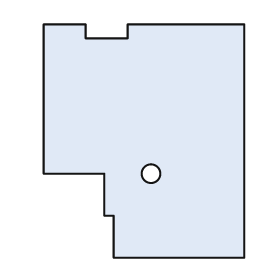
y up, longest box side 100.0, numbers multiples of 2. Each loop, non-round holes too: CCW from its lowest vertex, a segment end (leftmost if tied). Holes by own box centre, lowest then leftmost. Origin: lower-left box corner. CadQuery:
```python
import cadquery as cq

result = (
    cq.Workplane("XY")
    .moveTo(30.0, 0.0)
    .lineTo(86.0, 0.0)
    .lineTo(86.0, 100.0)
    .lineTo(36.0, 100.0)
    .lineTo(36.0, 94.0)
    .lineTo(18.0, 94.0)
    .lineTo(18.0, 100.0)
    .lineTo(0.0, 100.0)
    .lineTo(0.0, 36.0)
    .lineTo(26.0, 36.0)
    .lineTo(26.0, 18.0)
    .lineTo(30.0, 18.0)
    .close()
    .moveTo(46.0, 36.0)
    .circle(4.0)
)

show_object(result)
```